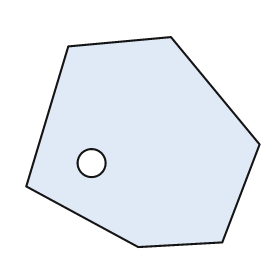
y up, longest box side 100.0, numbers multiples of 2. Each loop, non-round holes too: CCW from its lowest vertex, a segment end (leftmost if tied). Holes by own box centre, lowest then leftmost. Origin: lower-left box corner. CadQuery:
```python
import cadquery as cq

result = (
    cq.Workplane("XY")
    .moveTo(48.0, 0.0)
    .lineTo(84.0, 2.0)
    .lineTo(100.0, 44.0)
    .lineTo(62.0, 90.0)
    .lineTo(18.0, 86.0)
    .lineTo(0.0, 26.0)
    .close()
    .moveTo(28.0, 36.0)
    .circle(6.0)
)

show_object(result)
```